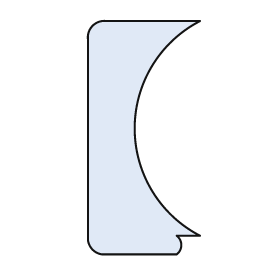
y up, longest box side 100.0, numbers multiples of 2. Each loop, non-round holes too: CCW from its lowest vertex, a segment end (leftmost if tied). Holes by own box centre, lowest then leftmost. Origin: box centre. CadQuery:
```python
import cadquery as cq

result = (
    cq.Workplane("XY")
    .moveTo(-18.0, -50.0)
    .lineTo(14.0, -50.0)
    .threePointArc((16.0, -46.0), (14.0, -42.0))
    .lineTo(24.0, -42.0)
    .threePointArc((-4.0, 4.0), (24.0, 50.0))
    .lineTo(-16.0, 50.0)
    .threePointArc((-22.0, 48.0), (-24.0, 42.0))
    .lineTo(-24.0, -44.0)
    .threePointArc((-22.0, -48.0), (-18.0, -50.0))
    .close()
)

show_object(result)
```